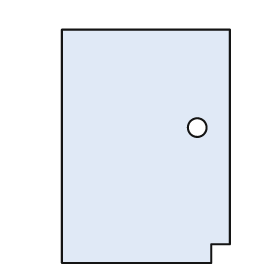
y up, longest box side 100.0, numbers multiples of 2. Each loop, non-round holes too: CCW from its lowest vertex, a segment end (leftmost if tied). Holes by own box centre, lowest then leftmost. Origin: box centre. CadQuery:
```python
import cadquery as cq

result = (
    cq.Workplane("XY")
    .moveTo(-36.0, -50.0)
    .lineTo(28.0, -50.0)
    .lineTo(28.0, -42.0)
    .lineTo(36.0, -42.0)
    .lineTo(36.0, 50.0)
    .lineTo(-36.0, 50.0)
    .close()
    .moveTo(22.0, 8.0)
    .circle(4.0)
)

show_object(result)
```